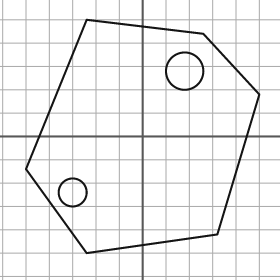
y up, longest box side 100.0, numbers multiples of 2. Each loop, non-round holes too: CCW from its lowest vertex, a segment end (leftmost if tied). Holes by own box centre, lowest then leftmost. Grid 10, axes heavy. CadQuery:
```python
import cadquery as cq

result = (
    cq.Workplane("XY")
    .moveTo(-24.0, -50.0)
    .lineTo(32.0, -42.0)
    .lineTo(50.0, 18.0)
    .lineTo(26.0, 44.0)
    .lineTo(-24.0, 50.0)
    .lineTo(-50.0, -14.0)
    .close()
    .moveTo(-30.0, -24.0)
    .circle(6.0)
    .moveTo(18.0, 28.0)
    .circle(8.0)
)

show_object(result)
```